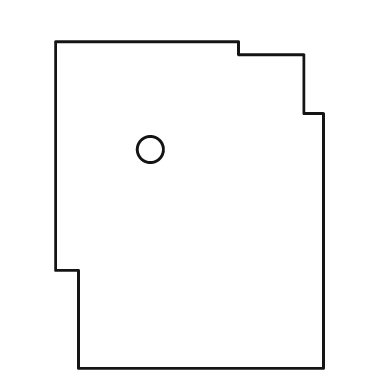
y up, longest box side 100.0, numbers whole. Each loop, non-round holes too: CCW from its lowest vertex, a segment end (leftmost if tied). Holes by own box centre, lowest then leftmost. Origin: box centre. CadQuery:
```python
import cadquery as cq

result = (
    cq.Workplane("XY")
    .moveTo(-34.0, -50.0)
    .lineTo(41.0, -50.0)
    .lineTo(41.0, 28.0)
    .lineTo(35.0, 28.0)
    .lineTo(35.0, 46.0)
    .lineTo(15.0, 46.0)
    .lineTo(15.0, 50.0)
    .lineTo(-41.0, 50.0)
    .lineTo(-41.0, -20.0)
    .lineTo(-34.0, -20.0)
    .close()
    .moveTo(-12.0, 17.0)
    .circle(4.0)
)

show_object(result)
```